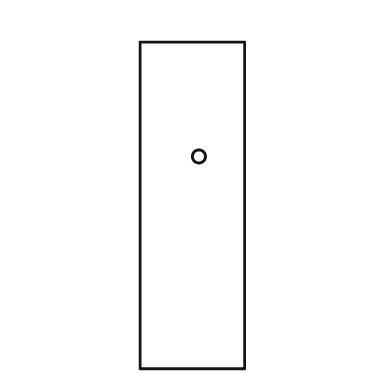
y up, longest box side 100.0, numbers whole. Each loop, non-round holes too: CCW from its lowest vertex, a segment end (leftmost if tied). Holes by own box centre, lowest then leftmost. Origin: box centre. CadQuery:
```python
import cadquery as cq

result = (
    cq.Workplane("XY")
    .moveTo(-16.0, -50.0)
    .lineTo(16.0, -50.0)
    .lineTo(16.0, 50.0)
    .lineTo(-16.0, 50.0)
    .close()
    .moveTo(2.0, 15.0)
    .circle(2.0)
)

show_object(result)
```